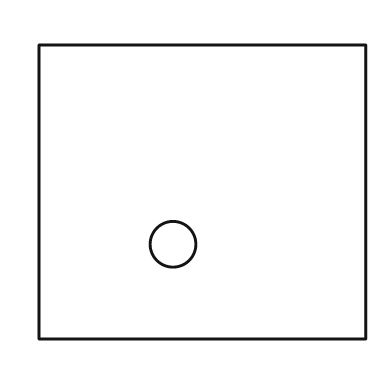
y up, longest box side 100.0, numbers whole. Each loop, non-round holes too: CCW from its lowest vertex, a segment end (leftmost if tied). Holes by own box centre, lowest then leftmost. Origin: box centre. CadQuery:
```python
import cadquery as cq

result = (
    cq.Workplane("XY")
    .moveTo(-50.0, -45.0)
    .lineTo(50.0, -45.0)
    .lineTo(50.0, 45.0)
    .lineTo(-50.0, 45.0)
    .close()
    .moveTo(-9.0, -16.0)
    .circle(7.0)
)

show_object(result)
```